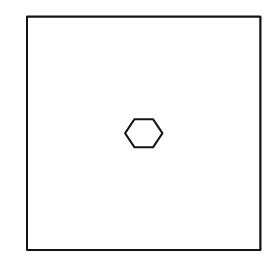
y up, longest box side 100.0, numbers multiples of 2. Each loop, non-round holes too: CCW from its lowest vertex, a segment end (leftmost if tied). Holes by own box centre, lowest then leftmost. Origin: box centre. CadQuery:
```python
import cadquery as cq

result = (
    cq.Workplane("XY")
    .moveTo(-50.0, -50.0)
    .lineTo(50.0, -50.0)
    .lineTo(50.0, 50.0)
    .lineTo(-50.0, 50.0)
    .close()
    .moveTo(-4.0, -6.0)
    .lineTo(4.0, -6.0)
    .lineTo(8.0, 0.0)
    .lineTo(4.0, 6.0)
    .lineTo(-4.0, 6.0)
    .lineTo(-8.0, 0.0)
    .close()
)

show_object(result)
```